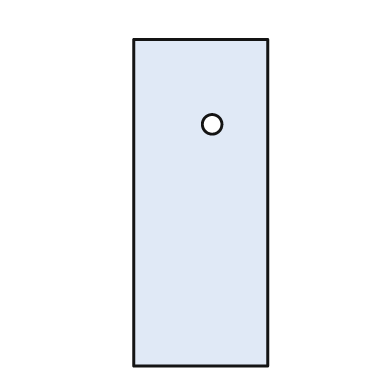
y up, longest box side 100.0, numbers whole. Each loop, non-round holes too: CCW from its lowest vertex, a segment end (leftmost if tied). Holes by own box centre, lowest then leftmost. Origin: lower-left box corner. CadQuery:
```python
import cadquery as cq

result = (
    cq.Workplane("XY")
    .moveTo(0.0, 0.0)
    .lineTo(41.0, 0.0)
    .lineTo(41.0, 100.0)
    .lineTo(0.0, 100.0)
    .close()
    .moveTo(24.0, 74.0)
    .circle(3.0)
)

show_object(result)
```